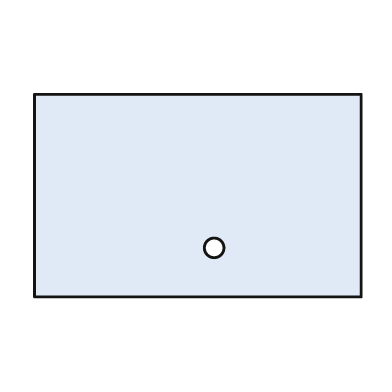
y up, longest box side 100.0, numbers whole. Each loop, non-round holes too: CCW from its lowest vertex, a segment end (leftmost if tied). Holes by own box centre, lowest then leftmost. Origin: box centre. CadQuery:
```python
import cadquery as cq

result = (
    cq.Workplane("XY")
    .moveTo(-50.0, -31.0)
    .lineTo(50.0, -31.0)
    .lineTo(50.0, 31.0)
    .lineTo(-50.0, 31.0)
    .close()
    .moveTo(5.0, -16.0)
    .circle(3.0)
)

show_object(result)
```